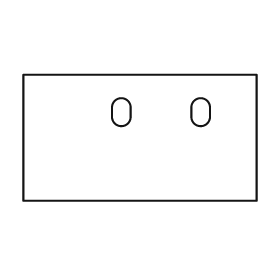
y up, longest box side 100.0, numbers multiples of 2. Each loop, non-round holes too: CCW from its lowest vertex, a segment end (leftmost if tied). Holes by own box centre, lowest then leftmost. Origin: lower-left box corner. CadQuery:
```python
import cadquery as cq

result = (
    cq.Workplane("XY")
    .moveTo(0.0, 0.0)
    .lineTo(100.0, 0.0)
    .lineTo(100.0, 54.0)
    .lineTo(0.0, 54.0)
    .close()
    .moveTo(38.0, 36.0)
    .threePointArc((42.0, 32.0), (46.0, 36.0))
    .lineTo(46.0, 40.0)
    .threePointArc((42.0, 44.0), (38.0, 40.0))
    .close()
    .moveTo(72.0, 36.0)
    .threePointArc((76.0, 32.0), (80.0, 36.0))
    .lineTo(80.0, 40.0)
    .threePointArc((76.0, 44.0), (72.0, 40.0))
    .close()
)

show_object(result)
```